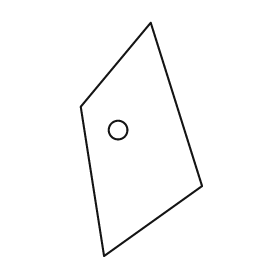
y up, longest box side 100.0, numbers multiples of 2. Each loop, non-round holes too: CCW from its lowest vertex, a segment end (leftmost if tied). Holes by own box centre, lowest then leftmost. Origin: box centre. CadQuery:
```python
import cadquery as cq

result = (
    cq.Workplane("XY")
    .moveTo(-16.0, -50.0)
    .lineTo(26.0, -20.0)
    .lineTo(4.0, 50.0)
    .lineTo(-26.0, 14.0)
    .close()
    .moveTo(-10.0, 4.0)
    .circle(4.0)
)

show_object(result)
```